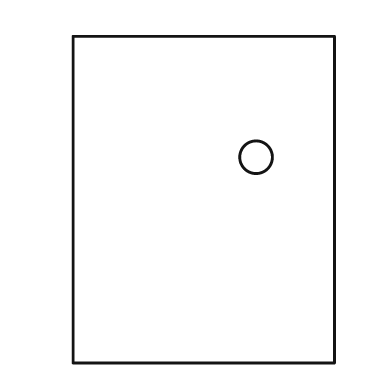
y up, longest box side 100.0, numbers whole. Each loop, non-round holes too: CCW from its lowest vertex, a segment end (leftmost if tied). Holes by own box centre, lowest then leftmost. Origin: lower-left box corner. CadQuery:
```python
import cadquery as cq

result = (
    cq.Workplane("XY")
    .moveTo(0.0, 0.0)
    .lineTo(80.0, 0.0)
    .lineTo(80.0, 100.0)
    .lineTo(0.0, 100.0)
    .close()
    .moveTo(56.0, 63.0)
    .circle(5.0)
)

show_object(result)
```